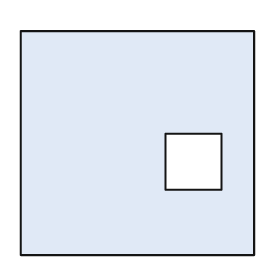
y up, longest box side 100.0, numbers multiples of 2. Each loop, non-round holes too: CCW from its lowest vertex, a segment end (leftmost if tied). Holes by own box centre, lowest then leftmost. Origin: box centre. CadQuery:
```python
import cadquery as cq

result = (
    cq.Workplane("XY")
    .moveTo(-50.0, -48.0)
    .lineTo(50.0, -48.0)
    .lineTo(50.0, 48.0)
    .lineTo(-50.0, 48.0)
    .close()
    .moveTo(12.0, -20.0)
    .lineTo(36.0, -20.0)
    .lineTo(36.0, 4.0)
    .lineTo(12.0, 4.0)
    .close()
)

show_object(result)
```